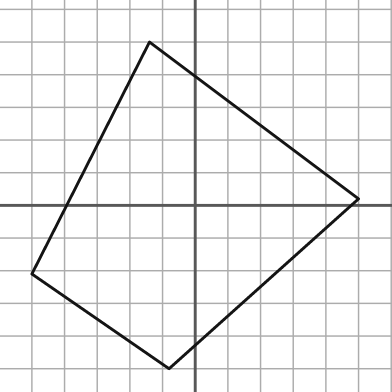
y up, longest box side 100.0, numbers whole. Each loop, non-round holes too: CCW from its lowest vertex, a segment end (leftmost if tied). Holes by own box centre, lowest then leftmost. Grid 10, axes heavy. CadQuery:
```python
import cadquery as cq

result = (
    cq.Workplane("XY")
    .moveTo(-8.0, -50.0)
    .lineTo(50.0, 2.0)
    .lineTo(-14.0, 50.0)
    .lineTo(-50.0, -21.0)
    .close()
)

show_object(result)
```